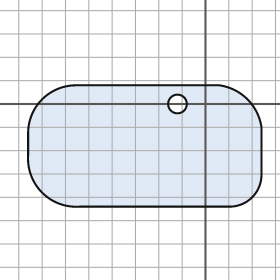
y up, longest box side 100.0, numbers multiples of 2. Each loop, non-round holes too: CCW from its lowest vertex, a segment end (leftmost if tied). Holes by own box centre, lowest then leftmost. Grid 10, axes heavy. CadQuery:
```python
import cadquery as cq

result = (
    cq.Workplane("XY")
    .moveTo(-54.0, -44.0)
    .lineTo(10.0, -44.0)
    .threePointArc((20.0, -40.0), (24.0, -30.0))
    .lineTo(24.0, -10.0)
    .threePointArc((18.0, 2.0), (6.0, 8.0))
    .lineTo(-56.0, 8.0)
    .threePointArc((-70.0, 2.0), (-76.0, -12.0))
    .lineTo(-76.0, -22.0)
    .threePointArc((-70.0, -38.0), (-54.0, -44.0))
    .close()
    .moveTo(-12.0, 0.0)
    .circle(4.0)
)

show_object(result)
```